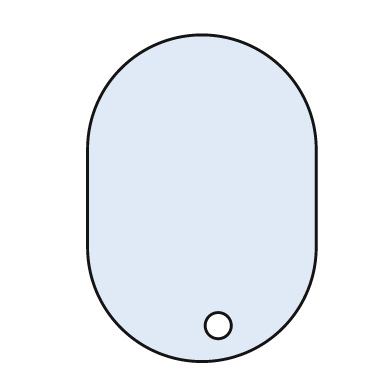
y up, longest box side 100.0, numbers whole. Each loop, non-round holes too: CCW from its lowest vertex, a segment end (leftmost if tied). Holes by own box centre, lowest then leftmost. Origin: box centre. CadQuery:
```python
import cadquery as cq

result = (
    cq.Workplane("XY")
    .moveTo(-35.0, -15.0)
    .threePointArc((0.0, -50.0), (35.0, -15.0))
    .lineTo(35.0, 15.0)
    .threePointArc((0.0, 50.0), (-35.0, 15.0))
    .close()
    .moveTo(5.0, -39.0)
    .circle(4.0)
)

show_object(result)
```